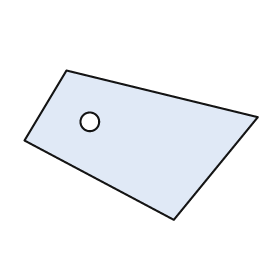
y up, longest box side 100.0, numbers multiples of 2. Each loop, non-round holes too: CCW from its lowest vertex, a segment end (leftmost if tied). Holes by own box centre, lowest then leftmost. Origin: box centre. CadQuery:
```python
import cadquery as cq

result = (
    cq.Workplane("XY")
    .moveTo(14.0, -32.0)
    .lineTo(50.0, 12.0)
    .lineTo(-32.0, 32.0)
    .lineTo(-50.0, 2.0)
    .close()
    .moveTo(-22.0, 10.0)
    .circle(4.0)
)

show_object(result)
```